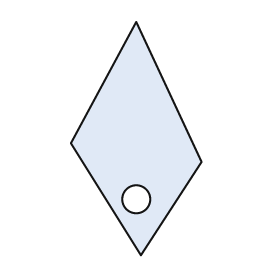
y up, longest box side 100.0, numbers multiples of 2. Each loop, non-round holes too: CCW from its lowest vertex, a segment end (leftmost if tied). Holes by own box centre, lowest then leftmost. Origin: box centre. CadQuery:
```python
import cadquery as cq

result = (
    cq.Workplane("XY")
    .moveTo(2.0, -50.0)
    .lineTo(28.0, -10.0)
    .lineTo(0.0, 50.0)
    .lineTo(-28.0, -2.0)
    .close()
    .moveTo(0.0, -26.0)
    .circle(6.0)
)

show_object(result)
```